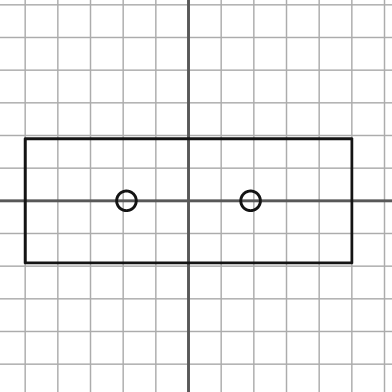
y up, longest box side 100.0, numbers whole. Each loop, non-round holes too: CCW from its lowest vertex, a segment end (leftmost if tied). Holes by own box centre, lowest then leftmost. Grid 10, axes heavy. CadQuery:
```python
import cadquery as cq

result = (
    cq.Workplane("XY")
    .moveTo(-50.0, -19.0)
    .lineTo(50.0, -19.0)
    .lineTo(50.0, 19.0)
    .lineTo(-50.0, 19.0)
    .close()
    .moveTo(-19.0, 0.0)
    .circle(3.0)
    .moveTo(19.0, 0.0)
    .circle(3.0)
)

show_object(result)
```